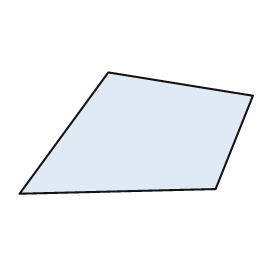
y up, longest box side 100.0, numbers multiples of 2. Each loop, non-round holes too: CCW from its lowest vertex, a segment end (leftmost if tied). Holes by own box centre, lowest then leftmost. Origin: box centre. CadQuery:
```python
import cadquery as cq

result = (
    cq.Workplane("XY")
    .moveTo(-50.0, -26.0)
    .lineTo(34.0, -24.0)
    .lineTo(50.0, 16.0)
    .lineTo(-12.0, 26.0)
    .close()
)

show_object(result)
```